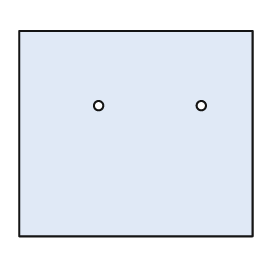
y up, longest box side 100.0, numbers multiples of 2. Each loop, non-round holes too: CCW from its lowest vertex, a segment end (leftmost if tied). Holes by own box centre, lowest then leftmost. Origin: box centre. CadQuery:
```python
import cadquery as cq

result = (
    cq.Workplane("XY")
    .moveTo(-50.0, -44.0)
    .lineTo(50.0, -44.0)
    .lineTo(50.0, 44.0)
    .lineTo(-50.0, 44.0)
    .close()
    .moveTo(-16.0, 12.0)
    .circle(2.0)
    .moveTo(28.0, 12.0)
    .circle(2.0)
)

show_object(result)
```